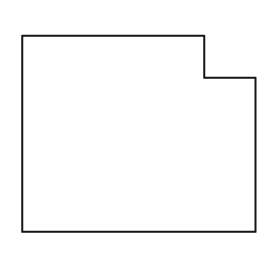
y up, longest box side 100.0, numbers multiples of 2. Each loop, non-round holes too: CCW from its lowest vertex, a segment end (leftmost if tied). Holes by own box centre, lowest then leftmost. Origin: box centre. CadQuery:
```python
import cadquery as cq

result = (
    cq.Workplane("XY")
    .moveTo(-50.0, -42.0)
    .lineTo(50.0, -42.0)
    .lineTo(50.0, 24.0)
    .lineTo(28.0, 24.0)
    .lineTo(28.0, 42.0)
    .lineTo(-50.0, 42.0)
    .close()
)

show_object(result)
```